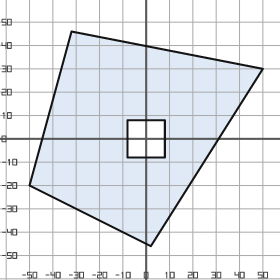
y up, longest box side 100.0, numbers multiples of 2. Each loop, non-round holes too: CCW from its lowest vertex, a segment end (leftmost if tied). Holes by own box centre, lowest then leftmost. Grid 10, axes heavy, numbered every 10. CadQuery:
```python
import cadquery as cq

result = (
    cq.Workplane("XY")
    .moveTo(2.0, -46.0)
    .lineTo(50.0, 30.0)
    .lineTo(-32.0, 46.0)
    .lineTo(-50.0, -20.0)
    .close()
    .moveTo(-8.0, -8.0)
    .lineTo(8.0, -8.0)
    .lineTo(8.0, 8.0)
    .lineTo(-8.0, 8.0)
    .close()
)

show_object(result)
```